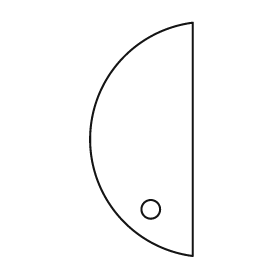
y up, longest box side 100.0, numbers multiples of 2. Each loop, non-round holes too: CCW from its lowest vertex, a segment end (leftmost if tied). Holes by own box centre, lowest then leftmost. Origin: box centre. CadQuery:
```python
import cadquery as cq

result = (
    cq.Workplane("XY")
    .moveTo(22.0, -50.0)
    .lineTo(22.0, 50.0)
    .threePointArc((-22.0, 0.0), (22.0, -50.0))
    .close()
    .moveTo(4.0, -30.0)
    .circle(4.0)
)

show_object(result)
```